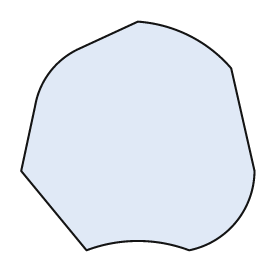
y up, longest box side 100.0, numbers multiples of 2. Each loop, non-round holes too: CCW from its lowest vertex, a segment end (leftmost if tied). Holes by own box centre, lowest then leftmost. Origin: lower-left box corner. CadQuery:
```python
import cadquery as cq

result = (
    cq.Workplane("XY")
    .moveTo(28.0, 0.0)
    .threePointArc((50.0, 4.0), (72.0, 0.0))
    .threePointArc((92.0, 12.0), (100.0, 34.0))
    .lineTo(90.0, 78.0)
    .threePointArc((72.0, 92.0), (50.0, 98.0))
    .lineTo(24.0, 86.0)
    .threePointArc((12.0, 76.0), (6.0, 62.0))
    .lineTo(0.0, 34.0)
    .close()
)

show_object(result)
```